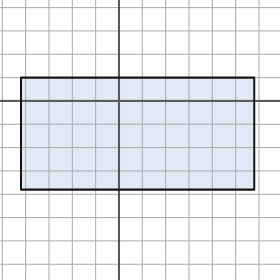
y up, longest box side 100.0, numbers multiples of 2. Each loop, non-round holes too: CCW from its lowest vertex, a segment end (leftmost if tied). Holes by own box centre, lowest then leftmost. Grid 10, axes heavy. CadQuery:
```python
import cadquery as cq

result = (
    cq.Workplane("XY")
    .moveTo(-42.0, -38.0)
    .lineTo(58.0, -38.0)
    .lineTo(58.0, 10.0)
    .lineTo(-42.0, 10.0)
    .close()
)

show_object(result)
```